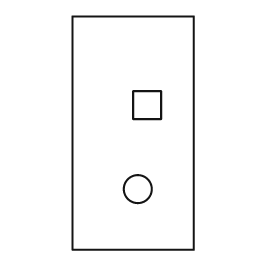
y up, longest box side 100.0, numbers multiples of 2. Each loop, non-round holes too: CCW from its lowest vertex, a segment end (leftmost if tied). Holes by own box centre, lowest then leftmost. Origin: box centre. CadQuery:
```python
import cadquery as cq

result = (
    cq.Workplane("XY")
    .moveTo(-26.0, -50.0)
    .lineTo(26.0, -50.0)
    .lineTo(26.0, 50.0)
    .lineTo(-26.0, 50.0)
    .close()
    .moveTo(2.0, -24.0)
    .circle(6.0)
    .moveTo(0.0, 6.0)
    .lineTo(12.0, 6.0)
    .lineTo(12.0, 18.0)
    .lineTo(0.0, 18.0)
    .close()
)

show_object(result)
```